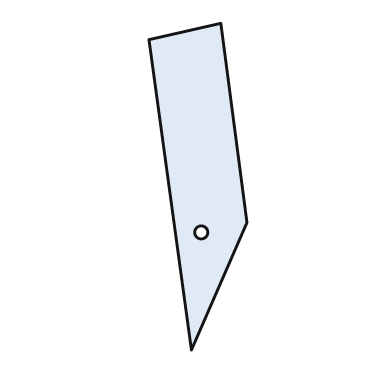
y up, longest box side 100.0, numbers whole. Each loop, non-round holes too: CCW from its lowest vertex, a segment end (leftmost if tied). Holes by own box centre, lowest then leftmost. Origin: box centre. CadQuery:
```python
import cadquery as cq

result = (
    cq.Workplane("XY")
    .moveTo(-2.0, -50.0)
    .lineTo(15.0, -11.0)
    .lineTo(7.0, 50.0)
    .lineTo(-15.0, 45.0)
    .close()
    .moveTo(1.0, -14.0)
    .circle(2.0)
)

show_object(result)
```